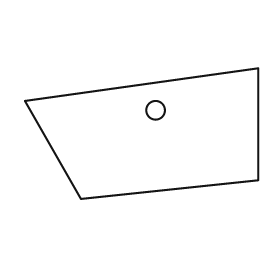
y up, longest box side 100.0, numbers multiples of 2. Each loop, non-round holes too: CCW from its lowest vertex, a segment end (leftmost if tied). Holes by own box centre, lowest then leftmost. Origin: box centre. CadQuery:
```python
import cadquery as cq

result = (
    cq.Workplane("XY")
    .moveTo(-26.0, -28.0)
    .lineTo(50.0, -20.0)
    .lineTo(50.0, 28.0)
    .lineTo(-50.0, 14.0)
    .close()
    .moveTo(6.0, 10.0)
    .circle(4.0)
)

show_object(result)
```